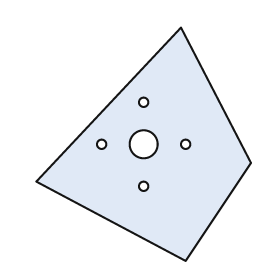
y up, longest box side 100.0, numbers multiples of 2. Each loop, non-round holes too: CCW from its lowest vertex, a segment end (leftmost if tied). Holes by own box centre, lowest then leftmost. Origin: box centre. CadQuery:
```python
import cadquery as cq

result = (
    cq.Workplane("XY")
    .moveTo(18.0, -50.0)
    .lineTo(46.0, -8.0)
    .lineTo(16.0, 50.0)
    .lineTo(-46.0, -16.0)
    .close()
    .moveTo(0.0, -18.0)
    .circle(2.0)
    .moveTo(-18.0, 0.0)
    .circle(2.0)
    .moveTo(0.0, 0.0)
    .circle(6.0)
    .moveTo(18.0, 0.0)
    .circle(2.0)
    .moveTo(0.0, 18.0)
    .circle(2.0)
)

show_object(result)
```